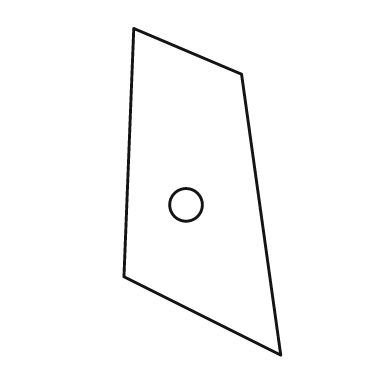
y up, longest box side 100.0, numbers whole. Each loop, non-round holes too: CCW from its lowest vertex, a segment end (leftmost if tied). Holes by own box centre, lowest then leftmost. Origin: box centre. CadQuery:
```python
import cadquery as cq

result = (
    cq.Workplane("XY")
    .moveTo(24.0, -50.0)
    .lineTo(12.0, 36.0)
    .lineTo(-21.0, 50.0)
    .lineTo(-24.0, -26.0)
    .close()
    .moveTo(-5.0, -4.0)
    .circle(5.0)
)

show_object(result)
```